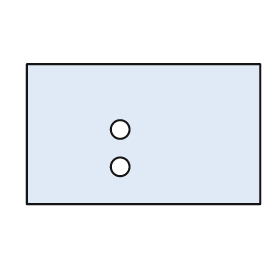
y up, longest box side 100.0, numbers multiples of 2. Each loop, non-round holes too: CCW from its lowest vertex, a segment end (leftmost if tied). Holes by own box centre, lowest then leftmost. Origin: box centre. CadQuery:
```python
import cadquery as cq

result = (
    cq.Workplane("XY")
    .moveTo(-50.0, -30.0)
    .lineTo(50.0, -30.0)
    .lineTo(50.0, 30.0)
    .lineTo(-50.0, 30.0)
    .close()
    .moveTo(-10.0, -14.0)
    .circle(4.0)
    .moveTo(-10.0, 2.0)
    .circle(4.0)
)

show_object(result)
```